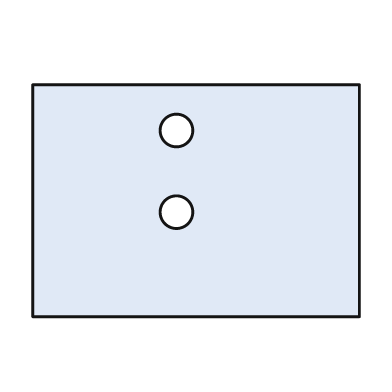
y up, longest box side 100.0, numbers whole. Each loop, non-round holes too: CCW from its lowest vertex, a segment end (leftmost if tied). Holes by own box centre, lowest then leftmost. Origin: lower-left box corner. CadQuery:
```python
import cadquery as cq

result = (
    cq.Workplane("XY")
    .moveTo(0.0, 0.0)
    .lineTo(100.0, 0.0)
    .lineTo(100.0, 71.0)
    .lineTo(0.0, 71.0)
    .close()
    .moveTo(44.0, 32.0)
    .circle(5.0)
    .moveTo(44.0, 57.0)
    .circle(5.0)
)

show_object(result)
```